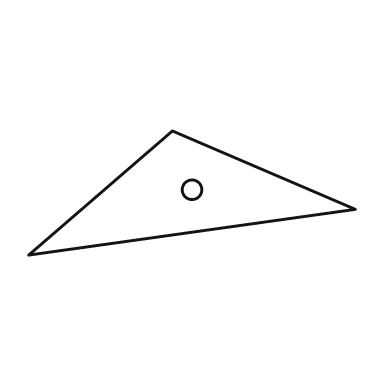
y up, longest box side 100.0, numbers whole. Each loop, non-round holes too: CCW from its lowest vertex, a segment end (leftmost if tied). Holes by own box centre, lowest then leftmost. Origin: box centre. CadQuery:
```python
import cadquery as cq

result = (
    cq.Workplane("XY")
    .moveTo(-50.0, -19.0)
    .lineTo(50.0, -5.0)
    .lineTo(-6.0, 19.0)
    .close()
    .moveTo(0.0, 1.0)
    .circle(3.0)
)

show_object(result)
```